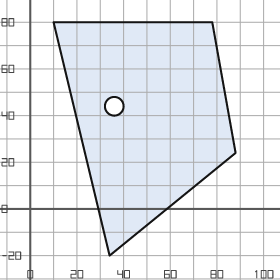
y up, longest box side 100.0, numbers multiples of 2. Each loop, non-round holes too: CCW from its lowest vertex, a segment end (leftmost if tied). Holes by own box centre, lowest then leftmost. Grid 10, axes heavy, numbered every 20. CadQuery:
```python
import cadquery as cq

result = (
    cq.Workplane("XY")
    .moveTo(34.0, -20.0)
    .lineTo(88.0, 24.0)
    .lineTo(78.0, 80.0)
    .lineTo(10.0, 80.0)
    .close()
    .moveTo(36.0, 44.0)
    .circle(4.0)
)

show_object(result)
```